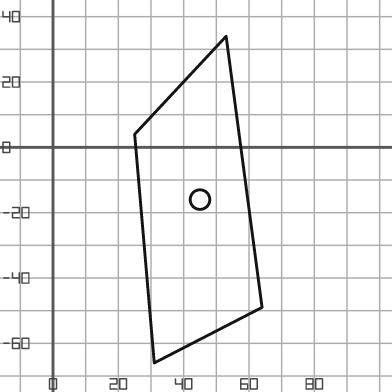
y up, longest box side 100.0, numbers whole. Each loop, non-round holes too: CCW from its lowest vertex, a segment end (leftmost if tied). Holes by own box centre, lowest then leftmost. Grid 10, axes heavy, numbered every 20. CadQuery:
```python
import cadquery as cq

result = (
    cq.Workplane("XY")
    .moveTo(31.0, -66.0)
    .lineTo(64.0, -49.0)
    .lineTo(53.0, 34.0)
    .lineTo(25.0, 4.0)
    .close()
    .moveTo(45.0, -16.0)
    .circle(3.0)
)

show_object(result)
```